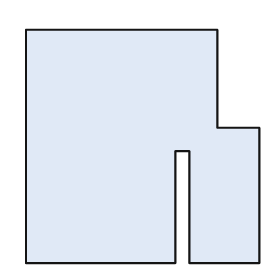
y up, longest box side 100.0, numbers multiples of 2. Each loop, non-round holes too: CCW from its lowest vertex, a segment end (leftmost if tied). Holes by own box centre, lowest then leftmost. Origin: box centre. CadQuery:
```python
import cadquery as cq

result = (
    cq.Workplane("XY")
    .moveTo(-50.0, -50.0)
    .lineTo(14.0, -50.0)
    .lineTo(14.0, -2.0)
    .lineTo(20.0, -2.0)
    .lineTo(20.0, -50.0)
    .lineTo(50.0, -50.0)
    .lineTo(50.0, 8.0)
    .lineTo(32.0, 8.0)
    .lineTo(32.0, 50.0)
    .lineTo(-50.0, 50.0)
    .close()
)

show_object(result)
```